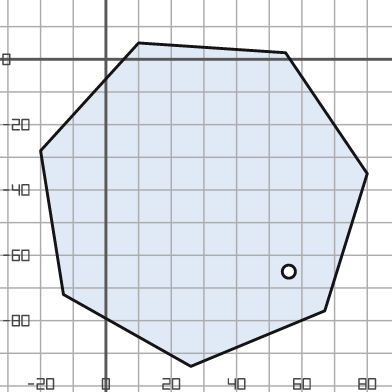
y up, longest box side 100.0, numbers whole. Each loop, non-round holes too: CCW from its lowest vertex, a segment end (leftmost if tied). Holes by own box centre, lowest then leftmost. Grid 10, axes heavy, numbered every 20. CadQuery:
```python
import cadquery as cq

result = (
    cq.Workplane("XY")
    .moveTo(26.0, -94.0)
    .lineTo(67.0, -77.0)
    .lineTo(80.0, -35.0)
    .lineTo(55.0, 2.0)
    .lineTo(10.0, 5.0)
    .lineTo(-20.0, -28.0)
    .lineTo(-13.0, -72.0)
    .close()
    .moveTo(56.0, -65.0)
    .circle(2.0)
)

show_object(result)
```